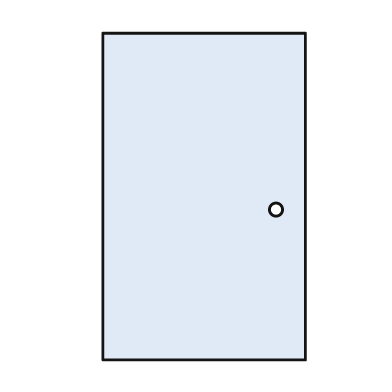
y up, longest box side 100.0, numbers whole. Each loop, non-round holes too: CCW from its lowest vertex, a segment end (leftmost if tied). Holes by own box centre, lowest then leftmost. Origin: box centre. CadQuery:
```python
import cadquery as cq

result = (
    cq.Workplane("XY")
    .moveTo(-31.0, -50.0)
    .lineTo(31.0, -50.0)
    .lineTo(31.0, 50.0)
    .lineTo(-31.0, 50.0)
    .close()
    .moveTo(22.0, -4.0)
    .circle(2.0)
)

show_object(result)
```